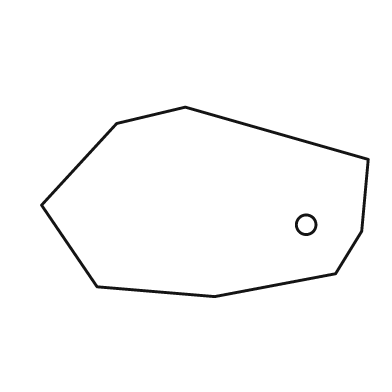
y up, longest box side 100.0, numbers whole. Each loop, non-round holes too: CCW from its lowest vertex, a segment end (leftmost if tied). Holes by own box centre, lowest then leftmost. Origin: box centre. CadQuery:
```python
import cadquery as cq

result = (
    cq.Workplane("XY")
    .moveTo(3.0, -29.0)
    .lineTo(40.0, -22.0)
    .lineTo(48.0, -9.0)
    .lineTo(50.0, 13.0)
    .lineTo(-6.0, 29.0)
    .lineTo(-27.0, 24.0)
    .lineTo(-50.0, -1.0)
    .lineTo(-33.0, -26.0)
    .close()
    .moveTo(31.0, -7.0)
    .circle(3.0)
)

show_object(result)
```